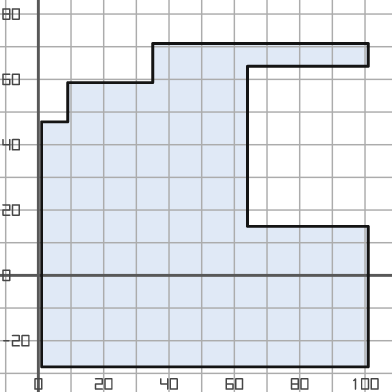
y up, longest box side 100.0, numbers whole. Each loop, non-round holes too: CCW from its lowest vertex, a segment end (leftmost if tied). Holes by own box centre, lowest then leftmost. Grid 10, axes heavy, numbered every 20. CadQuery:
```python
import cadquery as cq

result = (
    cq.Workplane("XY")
    .moveTo(1.0, -28.0)
    .lineTo(101.0, -28.0)
    .lineTo(101.0, 15.0)
    .lineTo(64.0, 15.0)
    .lineTo(64.0, 64.0)
    .lineTo(101.0, 64.0)
    .lineTo(101.0, 71.0)
    .lineTo(35.0, 71.0)
    .lineTo(35.0, 59.0)
    .lineTo(9.0, 59.0)
    .lineTo(9.0, 47.0)
    .lineTo(1.0, 47.0)
    .close()
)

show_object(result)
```